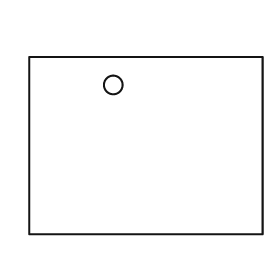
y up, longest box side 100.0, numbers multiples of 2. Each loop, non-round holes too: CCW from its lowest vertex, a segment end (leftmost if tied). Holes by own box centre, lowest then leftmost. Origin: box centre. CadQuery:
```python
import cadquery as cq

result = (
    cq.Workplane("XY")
    .moveTo(-50.0, -38.0)
    .lineTo(50.0, -38.0)
    .lineTo(50.0, 38.0)
    .lineTo(-50.0, 38.0)
    .close()
    .moveTo(-14.0, 26.0)
    .circle(4.0)
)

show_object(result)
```